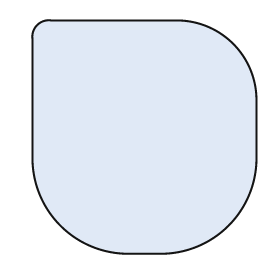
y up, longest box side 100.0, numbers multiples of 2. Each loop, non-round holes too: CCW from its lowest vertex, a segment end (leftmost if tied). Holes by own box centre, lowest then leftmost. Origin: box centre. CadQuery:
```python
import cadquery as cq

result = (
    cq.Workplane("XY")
    .moveTo(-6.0, -50.0)
    .lineTo(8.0, -50.0)
    .threePointArc((36.0, -38.0), (48.0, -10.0))
    .lineTo(48.0, 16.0)
    .threePointArc((38.0, 40.0), (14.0, 50.0))
    .lineTo(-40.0, 50.0)
    .threePointArc((-46.0, 48.0), (-48.0, 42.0))
    .lineTo(-48.0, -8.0)
    .threePointArc((-36.0, -38.0), (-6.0, -50.0))
    .close()
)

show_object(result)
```